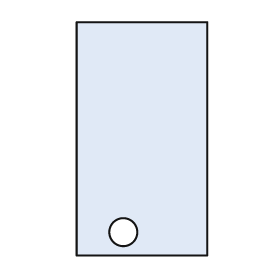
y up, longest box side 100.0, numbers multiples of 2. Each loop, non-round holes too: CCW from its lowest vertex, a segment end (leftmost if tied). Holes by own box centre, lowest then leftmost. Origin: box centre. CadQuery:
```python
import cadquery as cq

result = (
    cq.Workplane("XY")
    .moveTo(-28.0, -50.0)
    .lineTo(28.0, -50.0)
    .lineTo(28.0, 50.0)
    .lineTo(-28.0, 50.0)
    .close()
    .moveTo(-8.0, -40.0)
    .circle(6.0)
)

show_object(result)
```